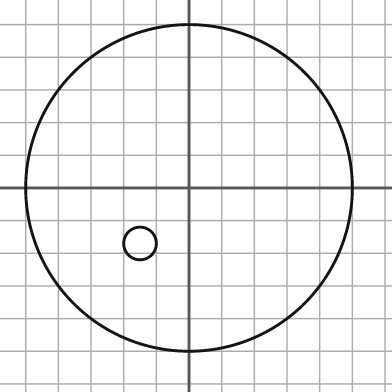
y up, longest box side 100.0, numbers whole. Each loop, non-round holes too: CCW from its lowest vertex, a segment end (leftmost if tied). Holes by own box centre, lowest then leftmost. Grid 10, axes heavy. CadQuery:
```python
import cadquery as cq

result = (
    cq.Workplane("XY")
    .moveTo(0.0, 0.0)
    .circle(50.0)
    .moveTo(-15.0, -17.0)
    .circle(5.0)
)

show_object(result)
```